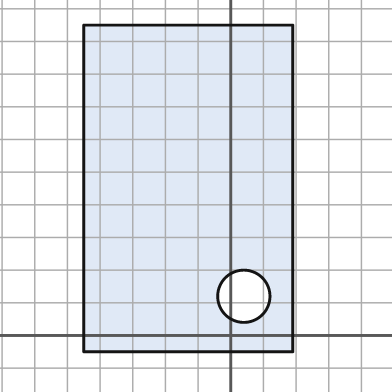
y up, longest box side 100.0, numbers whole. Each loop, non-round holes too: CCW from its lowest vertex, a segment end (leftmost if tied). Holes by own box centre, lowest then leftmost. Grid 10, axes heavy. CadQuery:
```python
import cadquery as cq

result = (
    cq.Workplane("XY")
    .moveTo(-45.0, -5.0)
    .lineTo(19.0, -5.0)
    .lineTo(19.0, 95.0)
    .lineTo(-45.0, 95.0)
    .close()
    .moveTo(4.0, 12.0)
    .circle(8.0)
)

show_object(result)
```